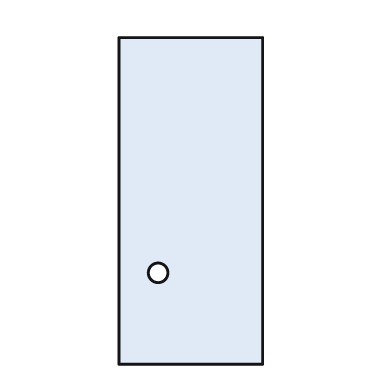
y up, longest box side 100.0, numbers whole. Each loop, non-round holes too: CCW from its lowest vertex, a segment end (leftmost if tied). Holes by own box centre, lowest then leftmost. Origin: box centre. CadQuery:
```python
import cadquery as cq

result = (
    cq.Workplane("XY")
    .moveTo(-22.0, -50.0)
    .lineTo(22.0, -50.0)
    .lineTo(22.0, 50.0)
    .lineTo(-22.0, 50.0)
    .close()
    .moveTo(-10.0, -22.0)
    .circle(3.0)
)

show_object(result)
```